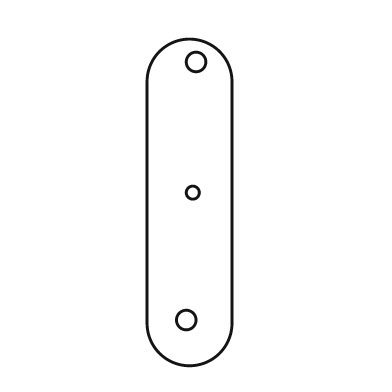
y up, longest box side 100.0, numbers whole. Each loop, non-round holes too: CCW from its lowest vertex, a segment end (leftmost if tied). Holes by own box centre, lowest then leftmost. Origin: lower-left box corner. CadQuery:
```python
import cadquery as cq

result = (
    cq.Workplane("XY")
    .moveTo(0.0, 13.0)
    .threePointArc((13.0, 0.0), (26.0, 13.0))
    .lineTo(26.0, 87.0)
    .threePointArc((13.0, 100.0), (0.0, 87.0))
    .close()
    .moveTo(12.0, 14.0)
    .circle(3.0)
    .moveTo(14.0, 53.0)
    .circle(2.0)
    .moveTo(15.0, 93.0)
    .circle(3.0)
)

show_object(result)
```